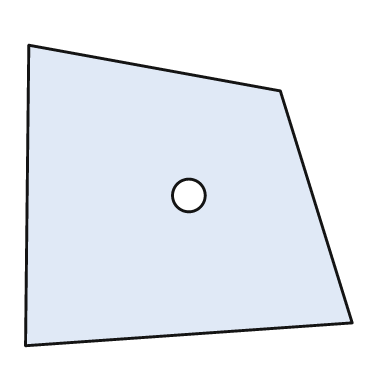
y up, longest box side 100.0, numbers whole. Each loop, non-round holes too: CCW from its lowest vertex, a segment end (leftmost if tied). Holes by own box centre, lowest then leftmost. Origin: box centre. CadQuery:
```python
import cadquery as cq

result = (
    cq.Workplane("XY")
    .moveTo(-50.0, -46.0)
    .lineTo(50.0, -39.0)
    .lineTo(28.0, 32.0)
    .lineTo(-49.0, 46.0)
    .close()
    .moveTo(0.0, 0.0)
    .circle(5.0)
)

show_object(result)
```